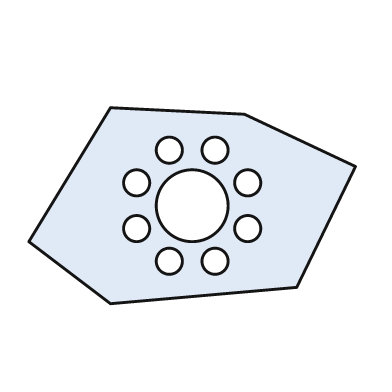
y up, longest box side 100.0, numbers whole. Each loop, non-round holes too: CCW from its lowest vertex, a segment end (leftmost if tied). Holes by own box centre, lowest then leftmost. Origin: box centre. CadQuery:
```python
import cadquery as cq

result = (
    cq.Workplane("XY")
    .moveTo(-25.0, -30.0)
    .lineTo(32.0, -25.0)
    .lineTo(50.0, 12.0)
    .lineTo(16.0, 28.0)
    .lineTo(-25.0, 30.0)
    .lineTo(-50.0, -11.0)
    .close()
    .moveTo(-7.0, -17.0)
    .circle(4.0)
    .moveTo(7.0, -17.0)
    .circle(4.0)
    .moveTo(-17.0, -7.0)
    .circle(4.0)
    .moveTo(17.0, -7.0)
    .circle(4.0)
    .moveTo(0.0, 0.0)
    .circle(11.0)
    .moveTo(-17.0, 7.0)
    .circle(4.0)
    .moveTo(17.0, 7.0)
    .circle(4.0)
    .moveTo(-7.0, 17.0)
    .circle(4.0)
    .moveTo(7.0, 17.0)
    .circle(4.0)
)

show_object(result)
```